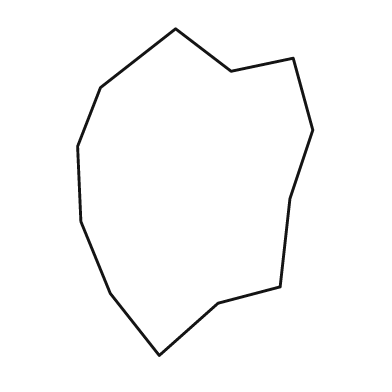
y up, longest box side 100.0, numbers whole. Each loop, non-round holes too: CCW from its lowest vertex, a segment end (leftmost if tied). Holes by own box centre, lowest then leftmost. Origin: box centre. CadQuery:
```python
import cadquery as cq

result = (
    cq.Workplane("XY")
    .moveTo(-11.0, -50.0)
    .lineTo(7.0, -34.0)
    .lineTo(26.0, -29.0)
    .lineTo(29.0, -2.0)
    .lineTo(36.0, 19.0)
    .lineTo(30.0, 41.0)
    .lineTo(11.0, 37.0)
    .lineTo(-6.0, 50.0)
    .lineTo(-29.0, 32.0)
    .lineTo(-36.0, 14.0)
    .lineTo(-35.0, -9.0)
    .lineTo(-26.0, -31.0)
    .close()
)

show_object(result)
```